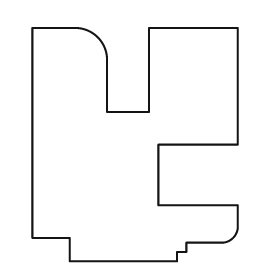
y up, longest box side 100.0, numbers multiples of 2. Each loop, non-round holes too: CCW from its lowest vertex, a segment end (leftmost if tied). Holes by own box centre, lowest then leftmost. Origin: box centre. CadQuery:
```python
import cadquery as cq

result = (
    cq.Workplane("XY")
    .moveTo(-28.0, -50.0)
    .lineTo(18.0, -50.0)
    .lineTo(18.0, -46.0)
    .lineTo(22.0, -46.0)
    .lineTo(22.0, -42.0)
    .lineTo(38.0, -42.0)
    .threePointArc((42.0, -40.0), (44.0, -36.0))
    .lineTo(44.0, -26.0)
    .lineTo(10.0, -26.0)
    .lineTo(10.0, 0.0)
    .lineTo(44.0, 0.0)
    .lineTo(44.0, 50.0)
    .lineTo(6.0, 50.0)
    .lineTo(6.0, 14.0)
    .lineTo(-12.0, 14.0)
    .lineTo(-12.0, 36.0)
    .threePointArc((-16.0, 46.0), (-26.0, 50.0))
    .lineTo(-44.0, 50.0)
    .lineTo(-44.0, -40.0)
    .lineTo(-28.0, -40.0)
    .close()
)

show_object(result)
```